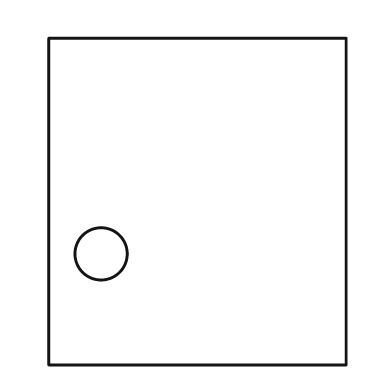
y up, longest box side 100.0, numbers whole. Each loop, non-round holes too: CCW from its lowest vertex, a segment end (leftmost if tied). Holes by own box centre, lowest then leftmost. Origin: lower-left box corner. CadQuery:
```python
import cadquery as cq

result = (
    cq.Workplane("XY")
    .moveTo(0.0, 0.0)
    .lineTo(91.0, 0.0)
    .lineTo(91.0, 100.0)
    .lineTo(0.0, 100.0)
    .close()
    .moveTo(16.0, 34.0)
    .circle(8.0)
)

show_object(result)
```